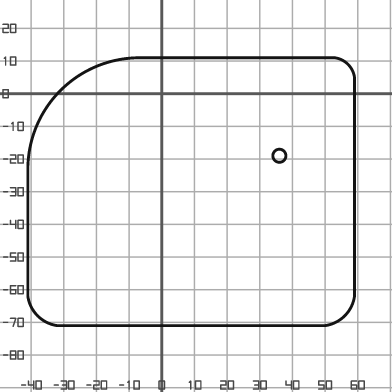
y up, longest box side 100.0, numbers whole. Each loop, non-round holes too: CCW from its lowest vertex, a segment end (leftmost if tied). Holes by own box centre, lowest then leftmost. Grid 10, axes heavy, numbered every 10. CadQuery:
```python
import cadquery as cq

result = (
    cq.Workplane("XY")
    .moveTo(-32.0, -71.0)
    .lineTo(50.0, -71.0)
    .threePointArc((56.0, -68.0), (59.0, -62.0))
    .lineTo(59.0, 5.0)
    .threePointArc((57.0, 9.0), (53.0, 11.0))
    .lineTo(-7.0, 11.0)
    .threePointArc((-31.0, 1.0), (-41.0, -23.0))
    .lineTo(-41.0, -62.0)
    .threePointArc((-38.0, -68.0), (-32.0, -71.0))
    .close()
    .moveTo(36.0, -19.0)
    .circle(2.0)
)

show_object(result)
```